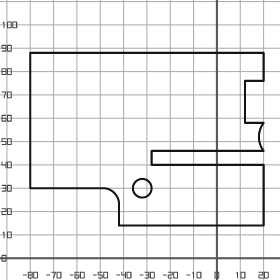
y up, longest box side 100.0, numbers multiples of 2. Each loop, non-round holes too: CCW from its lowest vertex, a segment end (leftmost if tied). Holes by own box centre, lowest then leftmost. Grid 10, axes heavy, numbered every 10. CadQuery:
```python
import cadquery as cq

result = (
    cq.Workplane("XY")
    .moveTo(-42.0, 14.0)
    .lineTo(20.0, 14.0)
    .lineTo(20.0, 40.0)
    .lineTo(-28.0, 40.0)
    .lineTo(-28.0, 46.0)
    .lineTo(20.0, 46.0)
    .threePointArc((18.0, 52.0), (20.0, 58.0))
    .lineTo(12.0, 58.0)
    .lineTo(12.0, 76.0)
    .lineTo(20.0, 76.0)
    .lineTo(20.0, 88.0)
    .lineTo(-80.0, 88.0)
    .lineTo(-80.0, 30.0)
    .lineTo(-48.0, 30.0)
    .threePointArc((-44.0, 28.0), (-42.0, 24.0))
    .close()
    .moveTo(-32.0, 30.0)
    .circle(4.0)
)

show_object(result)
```